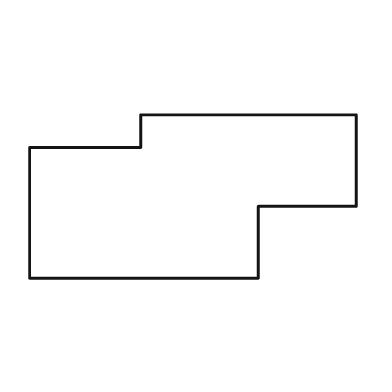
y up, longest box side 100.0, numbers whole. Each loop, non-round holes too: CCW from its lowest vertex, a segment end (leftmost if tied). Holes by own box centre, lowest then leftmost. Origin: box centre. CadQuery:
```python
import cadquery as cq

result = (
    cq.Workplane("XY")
    .moveTo(-50.0, -25.0)
    .lineTo(20.0, -25.0)
    .lineTo(20.0, -3.0)
    .lineTo(50.0, -3.0)
    .lineTo(50.0, 25.0)
    .lineTo(-16.0, 25.0)
    .lineTo(-16.0, 15.0)
    .lineTo(-50.0, 15.0)
    .close()
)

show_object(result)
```